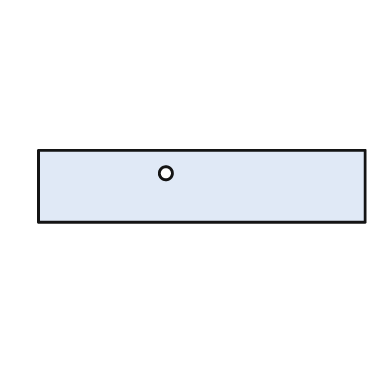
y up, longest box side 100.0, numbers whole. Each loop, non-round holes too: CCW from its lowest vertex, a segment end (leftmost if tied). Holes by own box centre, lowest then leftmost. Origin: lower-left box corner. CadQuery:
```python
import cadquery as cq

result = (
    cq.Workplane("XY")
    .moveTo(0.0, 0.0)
    .lineTo(100.0, 0.0)
    .lineTo(100.0, 22.0)
    .lineTo(0.0, 22.0)
    .close()
    .moveTo(39.0, 15.0)
    .circle(2.0)
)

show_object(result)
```